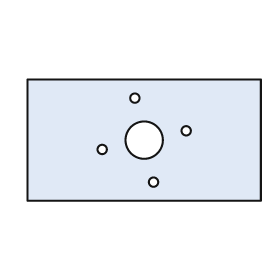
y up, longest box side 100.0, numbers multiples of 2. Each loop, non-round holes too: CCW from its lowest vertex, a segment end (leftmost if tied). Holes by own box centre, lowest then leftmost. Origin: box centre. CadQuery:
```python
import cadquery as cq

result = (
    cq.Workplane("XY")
    .moveTo(-50.0, -26.0)
    .lineTo(50.0, -26.0)
    .lineTo(50.0, 26.0)
    .lineTo(-50.0, 26.0)
    .close()
    .moveTo(4.0, -18.0)
    .circle(2.0)
    .moveTo(-18.0, -4.0)
    .circle(2.0)
    .moveTo(0.0, 0.0)
    .circle(8.0)
    .moveTo(18.0, 4.0)
    .circle(2.0)
    .moveTo(-4.0, 18.0)
    .circle(2.0)
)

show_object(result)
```